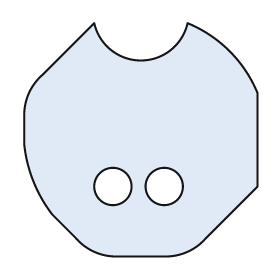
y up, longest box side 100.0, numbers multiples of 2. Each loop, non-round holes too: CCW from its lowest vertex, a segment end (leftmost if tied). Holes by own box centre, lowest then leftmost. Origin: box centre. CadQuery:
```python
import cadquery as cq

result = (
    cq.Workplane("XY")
    .moveTo(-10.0, -50.0)
    .lineTo(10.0, -50.0)
    .threePointArc((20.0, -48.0), (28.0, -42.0))
    .lineTo(50.0, -20.0)
    .lineTo(50.0, 20.0)
    .threePointArc((38.0, 38.0), (20.0, 50.0))
    .threePointArc((0.0, 34.0), (-20.0, 50.0))
    .lineTo(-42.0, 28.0)
    .threePointArc((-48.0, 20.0), (-50.0, 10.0))
    .lineTo(-50.0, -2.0)
    .threePointArc((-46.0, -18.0), (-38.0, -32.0))
    .lineTo(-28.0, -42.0)
    .threePointArc((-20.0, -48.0), (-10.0, -50.0))
    .close()
    .moveTo(-12.0, -20.0)
    .circle(8.0)
    .moveTo(10.0, -20.0)
    .circle(8.0)
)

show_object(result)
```